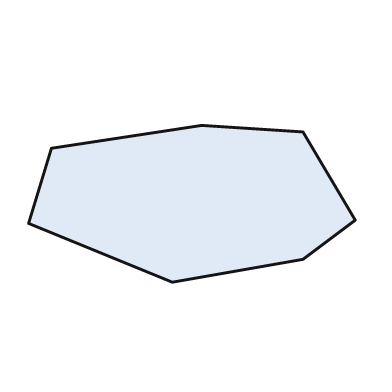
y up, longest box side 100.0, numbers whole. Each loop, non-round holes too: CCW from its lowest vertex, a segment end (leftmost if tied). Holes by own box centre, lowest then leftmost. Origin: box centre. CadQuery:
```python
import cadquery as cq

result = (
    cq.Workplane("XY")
    .moveTo(-6.0, -24.0)
    .lineTo(34.0, -17.0)
    .lineTo(50.0, -5.0)
    .lineTo(34.0, 22.0)
    .lineTo(3.0, 24.0)
    .lineTo(-43.0, 17.0)
    .lineTo(-50.0, -6.0)
    .close()
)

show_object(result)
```